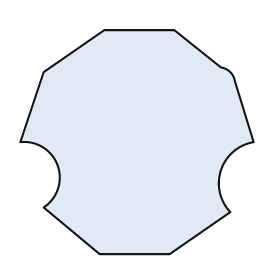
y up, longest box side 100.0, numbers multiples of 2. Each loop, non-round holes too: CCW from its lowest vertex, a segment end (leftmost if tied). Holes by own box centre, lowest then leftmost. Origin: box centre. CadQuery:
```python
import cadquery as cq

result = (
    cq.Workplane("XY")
    .moveTo(-16.0, -48.0)
    .lineTo(14.0, -48.0)
    .lineTo(40.0, -30.0)
    .threePointArc((36.0, -12.0), (50.0, 0.0))
    .lineTo(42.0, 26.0)
    .threePointArc((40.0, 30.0), (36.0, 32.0))
    .lineTo(16.0, 48.0)
    .lineTo(-14.0, 48.0)
    .lineTo(-40.0, 30.0)
    .lineTo(-50.0, 0.0)
    .threePointArc((-34.0, -10.0), (-40.0, -28.0))
    .close()
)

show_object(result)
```